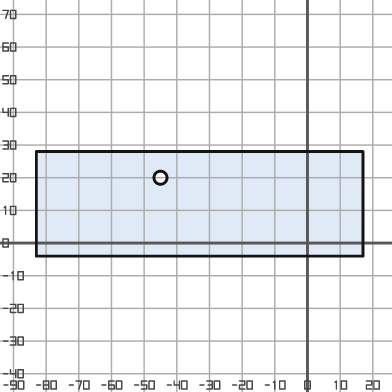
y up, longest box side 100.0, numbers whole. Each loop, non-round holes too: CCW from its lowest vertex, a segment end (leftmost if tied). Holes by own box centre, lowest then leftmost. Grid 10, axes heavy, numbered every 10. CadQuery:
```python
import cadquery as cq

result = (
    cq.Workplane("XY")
    .moveTo(-83.0, -4.0)
    .lineTo(17.0, -4.0)
    .lineTo(17.0, 28.0)
    .lineTo(-83.0, 28.0)
    .close()
    .moveTo(-45.0, 20.0)
    .circle(2.0)
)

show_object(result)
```